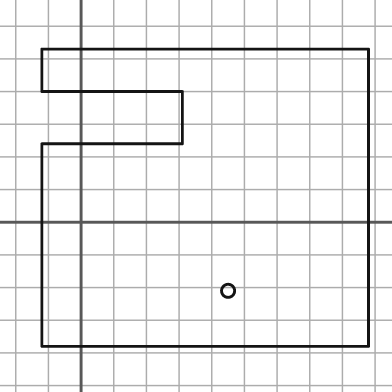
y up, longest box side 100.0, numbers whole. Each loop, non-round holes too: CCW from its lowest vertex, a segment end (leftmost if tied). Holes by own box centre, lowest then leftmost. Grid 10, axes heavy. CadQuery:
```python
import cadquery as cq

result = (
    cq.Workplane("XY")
    .moveTo(-12.0, -38.0)
    .lineTo(88.0, -38.0)
    .lineTo(88.0, 53.0)
    .lineTo(-12.0, 53.0)
    .lineTo(-12.0, 40.0)
    .lineTo(31.0, 40.0)
    .lineTo(31.0, 24.0)
    .lineTo(-12.0, 24.0)
    .close()
    .moveTo(45.0, -21.0)
    .circle(2.0)
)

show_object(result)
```